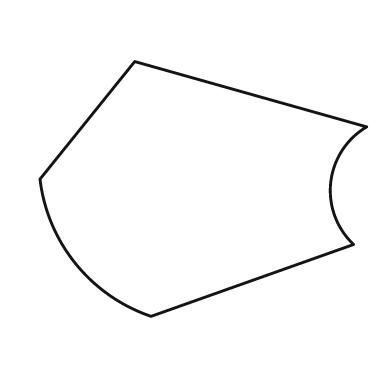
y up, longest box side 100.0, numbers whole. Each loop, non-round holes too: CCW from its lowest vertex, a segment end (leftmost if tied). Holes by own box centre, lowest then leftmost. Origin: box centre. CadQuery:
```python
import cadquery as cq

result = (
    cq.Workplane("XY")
    .moveTo(-16.0, -39.0)
    .lineTo(46.0, -17.0)
    .threePointArc((39.0, 2.0), (50.0, 19.0))
    .lineTo(-21.0, 39.0)
    .lineTo(-50.0, 3.0)
    .threePointArc((-39.0, -23.0), (-16.0, -39.0))
    .close()
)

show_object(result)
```